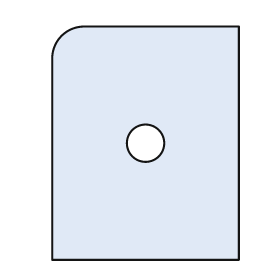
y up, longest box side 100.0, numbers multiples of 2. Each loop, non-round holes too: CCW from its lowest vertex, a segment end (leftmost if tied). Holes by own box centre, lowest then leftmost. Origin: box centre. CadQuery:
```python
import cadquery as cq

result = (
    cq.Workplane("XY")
    .moveTo(-40.0, -50.0)
    .lineTo(40.0, -50.0)
    .lineTo(40.0, 50.0)
    .lineTo(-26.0, 50.0)
    .threePointArc((-36.0, 46.0), (-40.0, 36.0))
    .close()
    .moveTo(0.0, 0.0)
    .circle(8.0)
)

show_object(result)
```